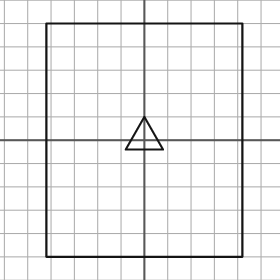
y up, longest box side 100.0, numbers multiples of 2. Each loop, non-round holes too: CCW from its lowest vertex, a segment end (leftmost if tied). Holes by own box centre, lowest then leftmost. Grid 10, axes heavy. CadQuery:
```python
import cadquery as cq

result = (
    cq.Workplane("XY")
    .moveTo(-42.0, -50.0)
    .lineTo(42.0, -50.0)
    .lineTo(42.0, 50.0)
    .lineTo(-42.0, 50.0)
    .close()
    .moveTo(-8.0, -4.0)
    .lineTo(8.0, -4.0)
    .lineTo(0.0, 10.0)
    .close()
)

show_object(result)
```